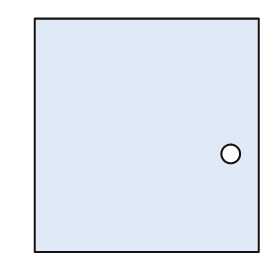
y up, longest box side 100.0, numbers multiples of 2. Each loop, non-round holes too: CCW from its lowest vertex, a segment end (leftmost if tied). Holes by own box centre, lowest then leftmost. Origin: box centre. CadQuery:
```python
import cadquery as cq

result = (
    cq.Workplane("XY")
    .moveTo(-48.0, -50.0)
    .lineTo(48.0, -50.0)
    .lineTo(48.0, 50.0)
    .lineTo(-48.0, 50.0)
    .close()
    .moveTo(36.0, -8.0)
    .circle(4.0)
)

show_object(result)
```